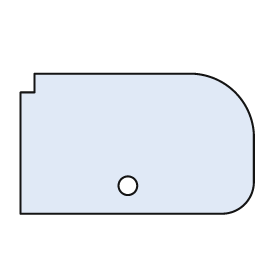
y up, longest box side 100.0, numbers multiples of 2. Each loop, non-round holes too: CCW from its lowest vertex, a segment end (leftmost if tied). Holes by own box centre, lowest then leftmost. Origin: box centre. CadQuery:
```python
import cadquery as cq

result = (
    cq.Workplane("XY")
    .moveTo(-50.0, -30.0)
    .lineTo(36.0, -30.0)
    .threePointArc((46.0, -26.0), (50.0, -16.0))
    .lineTo(50.0, 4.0)
    .threePointArc((42.0, 22.0), (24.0, 30.0))
    .lineTo(-44.0, 30.0)
    .lineTo(-44.0, 22.0)
    .lineTo(-50.0, 22.0)
    .close()
    .moveTo(-4.0, -18.0)
    .circle(4.0)
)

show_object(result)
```